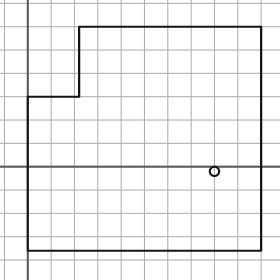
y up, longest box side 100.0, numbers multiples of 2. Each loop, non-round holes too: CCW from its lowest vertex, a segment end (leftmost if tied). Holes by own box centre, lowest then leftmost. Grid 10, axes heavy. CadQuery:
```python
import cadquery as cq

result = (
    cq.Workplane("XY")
    .moveTo(0.0, -36.0)
    .lineTo(100.0, -36.0)
    .lineTo(100.0, 60.0)
    .lineTo(22.0, 60.0)
    .lineTo(22.0, 30.0)
    .lineTo(0.0, 30.0)
    .close()
    .moveTo(80.0, -2.0)
    .circle(2.0)
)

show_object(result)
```